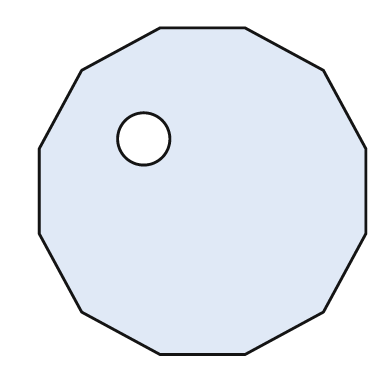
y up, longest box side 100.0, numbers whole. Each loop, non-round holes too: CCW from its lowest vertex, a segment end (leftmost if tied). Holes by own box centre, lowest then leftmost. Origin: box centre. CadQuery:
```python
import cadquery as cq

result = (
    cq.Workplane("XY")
    .moveTo(-13.0, -50.0)
    .lineTo(13.0, -50.0)
    .lineTo(37.0, -37.0)
    .lineTo(50.0, -13.0)
    .lineTo(50.0, 13.0)
    .lineTo(37.0, 37.0)
    .lineTo(13.0, 50.0)
    .lineTo(-13.0, 50.0)
    .lineTo(-37.0, 37.0)
    .lineTo(-50.0, 13.0)
    .lineTo(-50.0, -13.0)
    .lineTo(-37.0, -37.0)
    .close()
    .moveTo(-18.0, 16.0)
    .circle(8.0)
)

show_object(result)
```